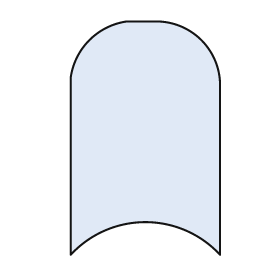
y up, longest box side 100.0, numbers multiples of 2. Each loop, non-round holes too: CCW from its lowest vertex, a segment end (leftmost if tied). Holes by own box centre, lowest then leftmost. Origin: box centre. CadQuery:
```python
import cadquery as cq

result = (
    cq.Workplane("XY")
    .moveTo(-32.0, -50.0)
    .threePointArc((0.0, -36.0), (32.0, -50.0))
    .lineTo(32.0, 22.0)
    .threePointArc((24.0, 42.0), (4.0, 50.0))
    .lineTo(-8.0, 50.0)
    .threePointArc((-24.0, 42.0), (-32.0, 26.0))
    .close()
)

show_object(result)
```